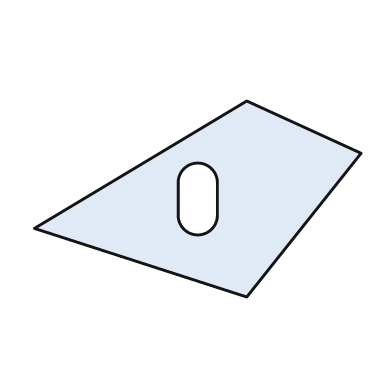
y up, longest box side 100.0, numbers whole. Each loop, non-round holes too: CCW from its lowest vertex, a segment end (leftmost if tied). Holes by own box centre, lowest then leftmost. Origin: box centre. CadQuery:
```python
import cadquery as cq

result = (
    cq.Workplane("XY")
    .moveTo(15.0, -30.0)
    .lineTo(50.0, 14.0)
    .lineTo(15.0, 30.0)
    .lineTo(-50.0, -9.0)
    .close()
    .moveTo(-6.0, -5.0)
    .threePointArc((0.0, -11.0), (6.0, -5.0))
    .lineTo(6.0, 5.0)
    .threePointArc((0.0, 11.0), (-6.0, 5.0))
    .close()
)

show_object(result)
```